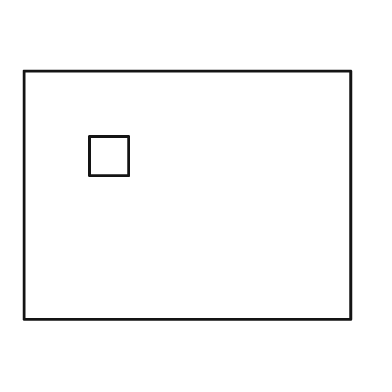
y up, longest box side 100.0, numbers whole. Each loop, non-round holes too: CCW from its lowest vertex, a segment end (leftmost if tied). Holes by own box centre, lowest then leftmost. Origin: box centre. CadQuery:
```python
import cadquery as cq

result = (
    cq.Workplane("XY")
    .moveTo(-50.0, -38.0)
    .lineTo(50.0, -38.0)
    .lineTo(50.0, 38.0)
    .lineTo(-50.0, 38.0)
    .close()
    .moveTo(-30.0, 6.0)
    .lineTo(-18.0, 6.0)
    .lineTo(-18.0, 18.0)
    .lineTo(-30.0, 18.0)
    .close()
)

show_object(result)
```